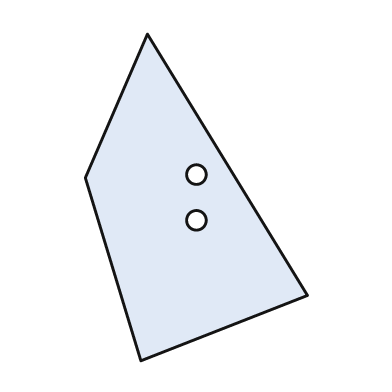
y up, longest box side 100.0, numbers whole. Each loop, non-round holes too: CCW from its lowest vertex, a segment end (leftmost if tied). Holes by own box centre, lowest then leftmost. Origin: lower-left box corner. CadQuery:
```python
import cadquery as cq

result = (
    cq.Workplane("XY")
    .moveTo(17.0, 0.0)
    .lineTo(68.0, 20.0)
    .lineTo(19.0, 100.0)
    .lineTo(0.0, 56.0)
    .close()
    .moveTo(34.0, 43.0)
    .circle(3.0)
    .moveTo(34.0, 57.0)
    .circle(3.0)
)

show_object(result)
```